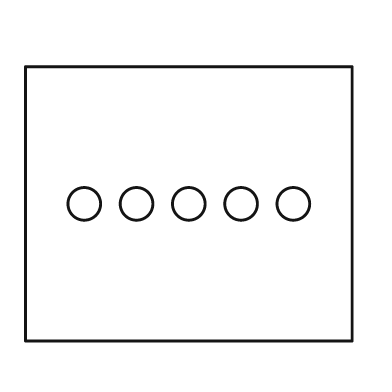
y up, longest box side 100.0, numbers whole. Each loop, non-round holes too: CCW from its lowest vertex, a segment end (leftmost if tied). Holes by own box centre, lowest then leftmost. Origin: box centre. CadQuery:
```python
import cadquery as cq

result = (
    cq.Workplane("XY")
    .moveTo(-50.0, -42.0)
    .lineTo(50.0, -42.0)
    .lineTo(50.0, 42.0)
    .lineTo(-50.0, 42.0)
    .close()
    .moveTo(-32.0, 0.0)
    .circle(5.0)
    .moveTo(-16.0, 0.0)
    .circle(5.0)
    .moveTo(0.0, 0.0)
    .circle(5.0)
    .moveTo(16.0, 0.0)
    .circle(5.0)
    .moveTo(32.0, 0.0)
    .circle(5.0)
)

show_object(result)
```